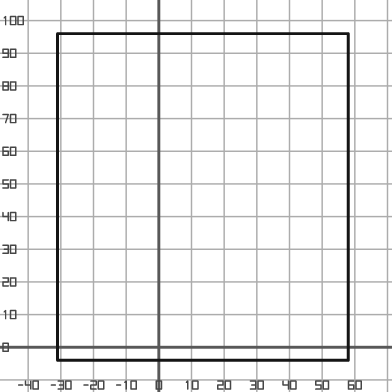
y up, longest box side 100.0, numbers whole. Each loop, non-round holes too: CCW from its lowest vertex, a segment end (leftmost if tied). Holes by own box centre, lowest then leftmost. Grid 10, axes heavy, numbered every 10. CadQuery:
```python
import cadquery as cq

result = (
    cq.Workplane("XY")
    .moveTo(-31.0, -4.0)
    .lineTo(58.0, -4.0)
    .lineTo(58.0, 96.0)
    .lineTo(-31.0, 96.0)
    .close()
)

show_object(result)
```